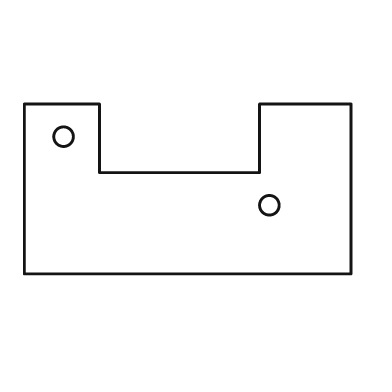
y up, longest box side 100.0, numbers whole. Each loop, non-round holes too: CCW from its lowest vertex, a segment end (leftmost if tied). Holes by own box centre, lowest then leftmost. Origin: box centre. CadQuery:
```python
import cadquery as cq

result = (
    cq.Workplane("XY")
    .moveTo(-50.0, -26.0)
    .lineTo(50.0, -26.0)
    .lineTo(50.0, 26.0)
    .lineTo(22.0, 26.0)
    .lineTo(22.0, 5.0)
    .lineTo(-27.0, 5.0)
    .lineTo(-27.0, 26.0)
    .lineTo(-50.0, 26.0)
    .close()
    .moveTo(25.0, -5.0)
    .circle(3.0)
    .moveTo(-38.0, 16.0)
    .circle(3.0)
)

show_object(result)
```